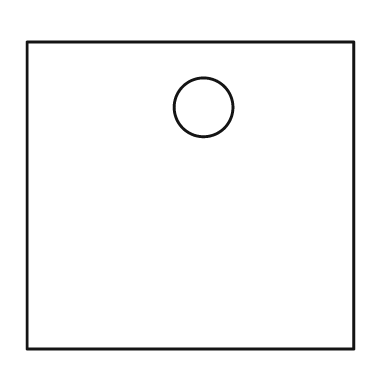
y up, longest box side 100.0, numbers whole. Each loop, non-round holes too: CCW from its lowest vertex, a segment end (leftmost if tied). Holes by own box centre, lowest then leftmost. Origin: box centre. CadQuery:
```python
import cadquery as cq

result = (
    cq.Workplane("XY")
    .moveTo(-50.0, -47.0)
    .lineTo(50.0, -47.0)
    .lineTo(50.0, 47.0)
    .lineTo(-50.0, 47.0)
    .close()
    .moveTo(4.0, 27.0)
    .circle(9.0)
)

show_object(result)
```